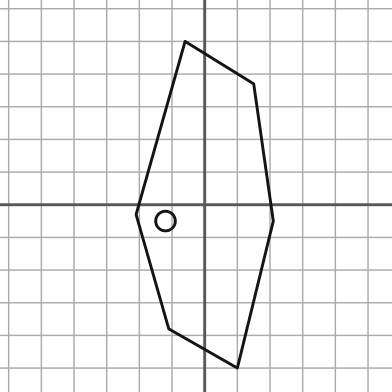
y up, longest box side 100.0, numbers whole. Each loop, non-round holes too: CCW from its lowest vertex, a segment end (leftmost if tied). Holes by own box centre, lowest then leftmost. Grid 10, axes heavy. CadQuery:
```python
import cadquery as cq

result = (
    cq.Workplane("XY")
    .moveTo(10.0, -50.0)
    .lineTo(21.0, -5.0)
    .lineTo(15.0, 37.0)
    .lineTo(-6.0, 50.0)
    .lineTo(-21.0, -3.0)
    .lineTo(-11.0, -38.0)
    .close()
    .moveTo(-12.0, -5.0)
    .circle(3.0)
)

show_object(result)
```